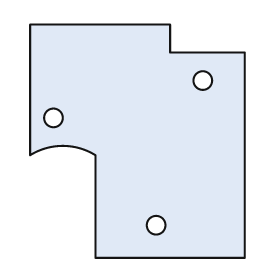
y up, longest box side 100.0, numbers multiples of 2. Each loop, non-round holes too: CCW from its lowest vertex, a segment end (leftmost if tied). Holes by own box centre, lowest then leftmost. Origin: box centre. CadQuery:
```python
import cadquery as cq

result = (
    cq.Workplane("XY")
    .moveTo(-18.0, -50.0)
    .lineTo(46.0, -50.0)
    .lineTo(46.0, 38.0)
    .lineTo(14.0, 38.0)
    .lineTo(14.0, 50.0)
    .lineTo(-46.0, 50.0)
    .lineTo(-46.0, -6.0)
    .threePointArc((-32.0, -2.0), (-18.0, -6.0))
    .close()
    .moveTo(8.0, -36.0)
    .circle(4.0)
    .moveTo(-36.0, 10.0)
    .circle(4.0)
    .moveTo(28.0, 26.0)
    .circle(4.0)
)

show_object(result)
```